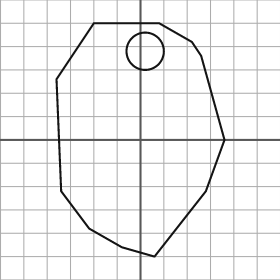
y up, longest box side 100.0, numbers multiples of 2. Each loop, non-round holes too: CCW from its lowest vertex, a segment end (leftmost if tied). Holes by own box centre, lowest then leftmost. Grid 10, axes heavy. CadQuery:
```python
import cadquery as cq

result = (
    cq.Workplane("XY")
    .moveTo(6.0, -50.0)
    .lineTo(28.0, -22.0)
    .lineTo(36.0, 0.0)
    .lineTo(26.0, 36.0)
    .lineTo(22.0, 42.0)
    .lineTo(8.0, 50.0)
    .lineTo(-20.0, 50.0)
    .lineTo(-36.0, 26.0)
    .lineTo(-34.0, -22.0)
    .lineTo(-22.0, -38.0)
    .lineTo(-8.0, -46.0)
    .close()
    .moveTo(2.0, 38.0)
    .circle(8.0)
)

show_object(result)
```